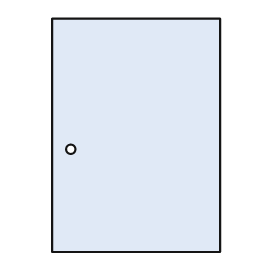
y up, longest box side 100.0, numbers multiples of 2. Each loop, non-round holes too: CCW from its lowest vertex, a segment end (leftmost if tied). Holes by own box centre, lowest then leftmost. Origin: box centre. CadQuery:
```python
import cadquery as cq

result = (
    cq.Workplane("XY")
    .moveTo(-36.0, -50.0)
    .lineTo(36.0, -50.0)
    .lineTo(36.0, 50.0)
    .lineTo(-36.0, 50.0)
    .close()
    .moveTo(-28.0, -6.0)
    .circle(2.0)
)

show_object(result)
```